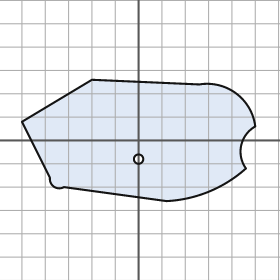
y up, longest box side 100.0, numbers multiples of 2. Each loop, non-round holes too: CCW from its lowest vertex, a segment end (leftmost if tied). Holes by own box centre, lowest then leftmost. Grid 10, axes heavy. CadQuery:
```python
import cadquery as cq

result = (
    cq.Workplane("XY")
    .moveTo(12.0, -26.0)
    .threePointArc((30.0, -22.0), (46.0, -12.0))
    .threePointArc((44.0, -2.0), (50.0, 6.0))
    .threePointArc((42.0, 20.0), (26.0, 24.0))
    .lineTo(-20.0, 26.0)
    .lineTo(-50.0, 8.0)
    .lineTo(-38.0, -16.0)
    .threePointArc((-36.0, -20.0), (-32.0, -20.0))
    .close()
    .moveTo(0.0, -8.0)
    .circle(2.0)
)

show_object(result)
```